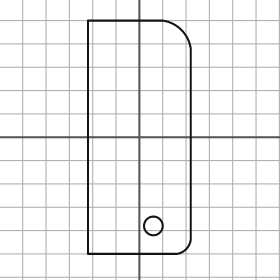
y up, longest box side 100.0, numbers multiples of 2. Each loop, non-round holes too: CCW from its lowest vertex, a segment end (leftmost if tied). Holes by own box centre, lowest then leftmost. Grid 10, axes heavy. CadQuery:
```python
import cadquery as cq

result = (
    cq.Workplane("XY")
    .moveTo(-22.0, -50.0)
    .lineTo(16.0, -50.0)
    .threePointArc((20.0, -48.0), (22.0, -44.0))
    .lineTo(22.0, 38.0)
    .threePointArc((18.0, 46.0), (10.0, 50.0))
    .lineTo(-22.0, 50.0)
    .close()
    .moveTo(6.0, -38.0)
    .circle(4.0)
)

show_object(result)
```